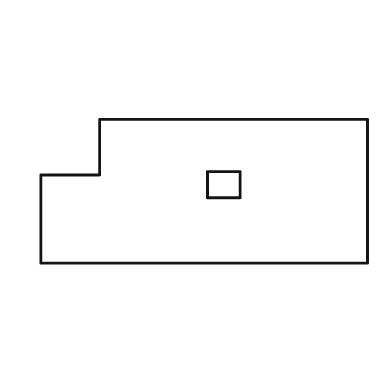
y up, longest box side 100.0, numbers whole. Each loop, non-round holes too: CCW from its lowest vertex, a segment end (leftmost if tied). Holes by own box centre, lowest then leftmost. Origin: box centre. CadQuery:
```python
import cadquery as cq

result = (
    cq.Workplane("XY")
    .moveTo(-50.0, -22.0)
    .lineTo(50.0, -22.0)
    .lineTo(50.0, 22.0)
    .lineTo(-32.0, 22.0)
    .lineTo(-32.0, 5.0)
    .lineTo(-50.0, 5.0)
    .close()
    .moveTo(1.0, -2.0)
    .lineTo(11.0, -2.0)
    .lineTo(11.0, 6.0)
    .lineTo(1.0, 6.0)
    .close()
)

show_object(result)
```